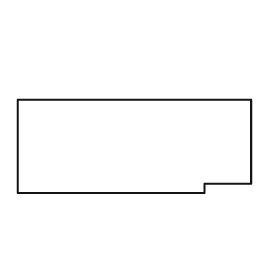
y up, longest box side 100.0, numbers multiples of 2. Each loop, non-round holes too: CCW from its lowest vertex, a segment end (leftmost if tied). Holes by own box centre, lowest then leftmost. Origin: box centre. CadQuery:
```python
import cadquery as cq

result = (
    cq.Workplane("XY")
    .moveTo(-50.0, -20.0)
    .lineTo(30.0, -20.0)
    .lineTo(30.0, -16.0)
    .lineTo(50.0, -16.0)
    .lineTo(50.0, 20.0)
    .lineTo(-50.0, 20.0)
    .close()
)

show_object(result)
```